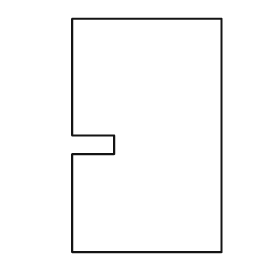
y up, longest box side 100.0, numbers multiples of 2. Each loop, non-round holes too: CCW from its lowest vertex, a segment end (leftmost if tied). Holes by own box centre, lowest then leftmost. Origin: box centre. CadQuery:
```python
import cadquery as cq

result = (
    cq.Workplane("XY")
    .moveTo(-32.0, -50.0)
    .lineTo(32.0, -50.0)
    .lineTo(32.0, 50.0)
    .lineTo(-32.0, 50.0)
    .lineTo(-32.0, 0.0)
    .lineTo(-14.0, 0.0)
    .lineTo(-14.0, -8.0)
    .lineTo(-32.0, -8.0)
    .close()
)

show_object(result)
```